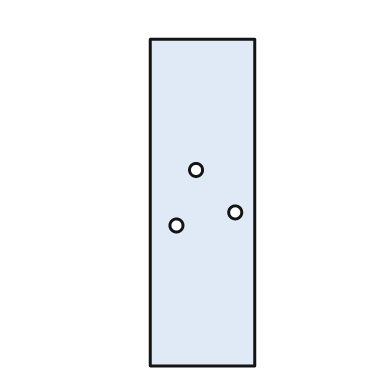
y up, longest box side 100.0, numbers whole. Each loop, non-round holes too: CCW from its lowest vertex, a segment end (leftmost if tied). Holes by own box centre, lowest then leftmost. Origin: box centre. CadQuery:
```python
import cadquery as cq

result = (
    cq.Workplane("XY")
    .moveTo(-16.0, -50.0)
    .lineTo(16.0, -50.0)
    .lineTo(16.0, 50.0)
    .lineTo(-16.0, 50.0)
    .close()
    .moveTo(-8.0, -7.0)
    .circle(2.0)
    .moveTo(10.0, -3.0)
    .circle(2.0)
    .moveTo(-2.0, 10.0)
    .circle(2.0)
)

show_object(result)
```